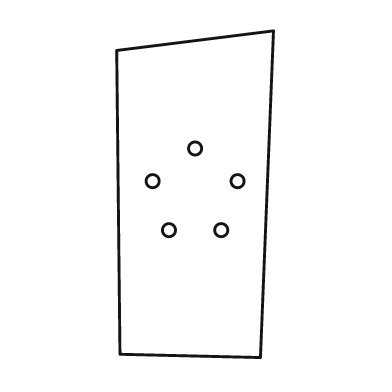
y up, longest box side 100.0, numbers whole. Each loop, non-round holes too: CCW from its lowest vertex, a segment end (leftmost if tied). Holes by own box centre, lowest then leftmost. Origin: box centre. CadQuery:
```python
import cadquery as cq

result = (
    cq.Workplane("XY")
    .moveTo(20.0, -50.0)
    .lineTo(24.0, 50.0)
    .lineTo(-24.0, 44.0)
    .lineTo(-23.0, -49.0)
    .close()
    .moveTo(-8.0, -11.0)
    .circle(2.0)
    .moveTo(8.0, -11.0)
    .circle(2.0)
    .moveTo(-13.0, 4.0)
    .circle(2.0)
    .moveTo(13.0, 4.0)
    .circle(2.0)
    .moveTo(0.0, 14.0)
    .circle(2.0)
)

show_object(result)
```